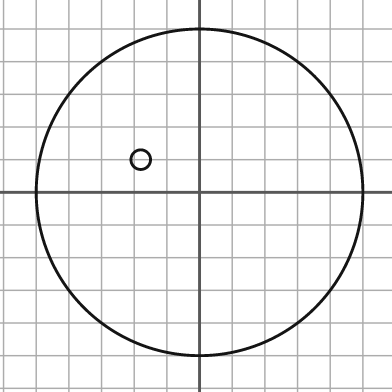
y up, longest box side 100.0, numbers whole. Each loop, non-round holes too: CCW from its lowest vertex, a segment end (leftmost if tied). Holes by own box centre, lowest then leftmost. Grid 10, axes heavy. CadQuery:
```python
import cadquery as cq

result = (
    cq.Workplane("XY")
    .moveTo(0.0, 0.0)
    .circle(50.0)
    .moveTo(-18.0, 10.0)
    .circle(3.0)
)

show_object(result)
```